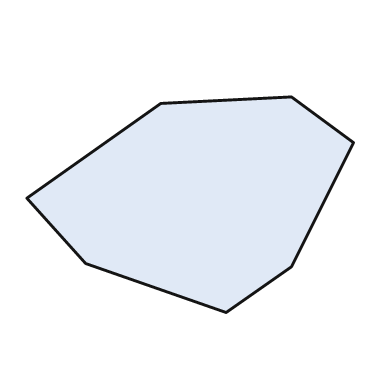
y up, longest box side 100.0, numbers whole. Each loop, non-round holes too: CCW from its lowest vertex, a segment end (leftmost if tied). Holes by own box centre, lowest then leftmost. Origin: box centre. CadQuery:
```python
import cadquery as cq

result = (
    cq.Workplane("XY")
    .moveTo(11.0, -33.0)
    .lineTo(31.0, -19.0)
    .lineTo(50.0, 19.0)
    .lineTo(31.0, 33.0)
    .lineTo(-9.0, 31.0)
    .lineTo(-50.0, 2.0)
    .lineTo(-32.0, -18.0)
    .close()
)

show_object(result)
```